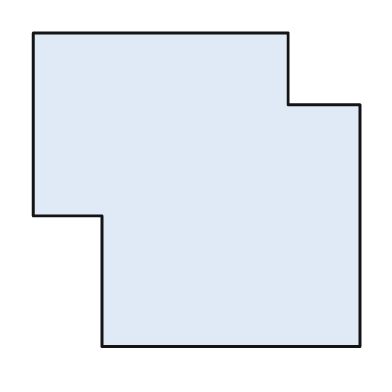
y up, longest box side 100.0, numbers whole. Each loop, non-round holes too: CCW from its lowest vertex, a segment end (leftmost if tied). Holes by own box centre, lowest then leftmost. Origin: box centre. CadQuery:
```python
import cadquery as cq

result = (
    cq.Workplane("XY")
    .moveTo(-29.0, -48.0)
    .lineTo(50.0, -48.0)
    .lineTo(50.0, 26.0)
    .lineTo(28.0, 26.0)
    .lineTo(28.0, 48.0)
    .lineTo(-50.0, 48.0)
    .lineTo(-50.0, -8.0)
    .lineTo(-29.0, -8.0)
    .close()
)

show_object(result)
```